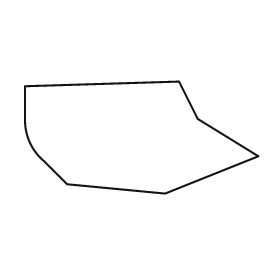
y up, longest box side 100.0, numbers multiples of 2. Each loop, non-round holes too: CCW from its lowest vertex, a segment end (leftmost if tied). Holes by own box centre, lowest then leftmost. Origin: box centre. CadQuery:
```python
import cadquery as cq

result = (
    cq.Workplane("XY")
    .moveTo(10.0, -24.0)
    .lineTo(50.0, -8.0)
    .lineTo(24.0, 8.0)
    .lineTo(16.0, 24.0)
    .lineTo(-50.0, 22.0)
    .lineTo(-50.0, 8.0)
    .threePointArc((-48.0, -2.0), (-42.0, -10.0))
    .lineTo(-32.0, -20.0)
    .close()
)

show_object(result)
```